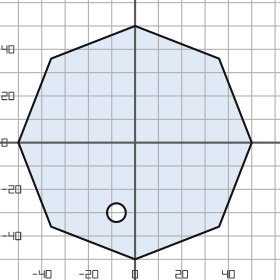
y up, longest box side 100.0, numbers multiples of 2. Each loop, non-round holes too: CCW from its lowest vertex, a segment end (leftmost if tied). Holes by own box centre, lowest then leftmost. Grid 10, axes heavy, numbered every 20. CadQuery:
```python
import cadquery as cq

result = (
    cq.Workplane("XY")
    .moveTo(0.0, -50.0)
    .lineTo(36.0, -36.0)
    .lineTo(50.0, 0.0)
    .lineTo(36.0, 36.0)
    .lineTo(0.0, 50.0)
    .lineTo(-36.0, 36.0)
    .lineTo(-50.0, 0.0)
    .lineTo(-36.0, -36.0)
    .close()
    .moveTo(-8.0, -30.0)
    .circle(4.0)
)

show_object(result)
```